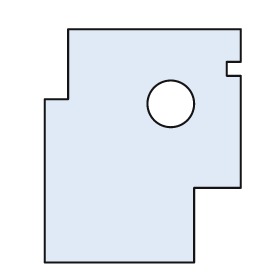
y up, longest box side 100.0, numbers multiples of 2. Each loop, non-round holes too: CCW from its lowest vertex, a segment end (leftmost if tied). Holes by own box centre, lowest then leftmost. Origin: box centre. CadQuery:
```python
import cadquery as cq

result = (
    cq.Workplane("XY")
    .moveTo(-42.0, -50.0)
    .lineTo(22.0, -50.0)
    .lineTo(22.0, -18.0)
    .lineTo(42.0, -18.0)
    .lineTo(42.0, 30.0)
    .lineTo(36.0, 30.0)
    .lineTo(36.0, 36.0)
    .lineTo(42.0, 36.0)
    .lineTo(42.0, 50.0)
    .lineTo(-32.0, 50.0)
    .lineTo(-32.0, 20.0)
    .lineTo(-42.0, 20.0)
    .close()
    .moveTo(12.0, 18.0)
    .circle(10.0)
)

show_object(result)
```